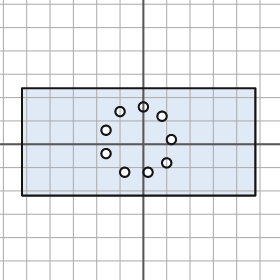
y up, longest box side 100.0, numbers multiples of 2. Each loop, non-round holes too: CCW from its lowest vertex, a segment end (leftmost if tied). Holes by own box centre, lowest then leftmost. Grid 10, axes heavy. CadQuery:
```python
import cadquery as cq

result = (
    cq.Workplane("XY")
    .moveTo(-52.0, -22.0)
    .lineTo(48.0, -22.0)
    .lineTo(48.0, 24.0)
    .lineTo(-52.0, 24.0)
    .close()
    .moveTo(-8.0, -12.0)
    .circle(2.0)
    .moveTo(2.0, -12.0)
    .circle(2.0)
    .moveTo(10.0, -8.0)
    .circle(2.0)
    .moveTo(-16.0, -4.0)
    .circle(2.0)
    .moveTo(12.0, 2.0)
    .circle(2.0)
    .moveTo(-16.0, 6.0)
    .circle(2.0)
    .moveTo(8.0, 12.0)
    .circle(2.0)
    .moveTo(-10.0, 14.0)
    .circle(2.0)
    .moveTo(0.0, 16.0)
    .circle(2.0)
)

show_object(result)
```